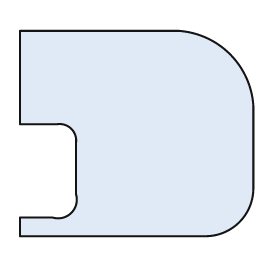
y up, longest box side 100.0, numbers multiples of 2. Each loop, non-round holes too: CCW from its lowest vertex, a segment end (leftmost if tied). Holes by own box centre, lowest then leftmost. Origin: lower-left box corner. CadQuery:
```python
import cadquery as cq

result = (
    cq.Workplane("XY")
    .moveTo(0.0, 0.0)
    .lineTo(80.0, 0.0)
    .threePointArc((94.0, 6.0), (100.0, 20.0))
    .lineTo(100.0, 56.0)
    .threePointArc((90.0, 78.0), (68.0, 88.0))
    .lineTo(0.0, 88.0)
    .lineTo(0.0, 48.0)
    .lineTo(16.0, 48.0)
    .threePointArc((22.0, 46.0), (24.0, 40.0))
    .lineTo(24.0, 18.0)
    .threePointArc((22.0, 10.0), (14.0, 8.0))
    .lineTo(0.0, 8.0)
    .close()
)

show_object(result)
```